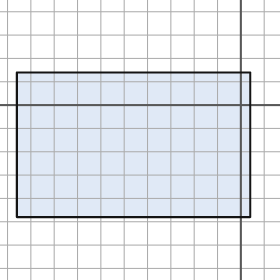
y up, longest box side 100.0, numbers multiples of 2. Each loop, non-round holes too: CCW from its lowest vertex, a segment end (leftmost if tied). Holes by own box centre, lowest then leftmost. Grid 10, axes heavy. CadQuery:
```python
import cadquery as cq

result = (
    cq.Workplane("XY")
    .moveTo(-96.0, -48.0)
    .lineTo(4.0, -48.0)
    .lineTo(4.0, 14.0)
    .lineTo(-96.0, 14.0)
    .close()
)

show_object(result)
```